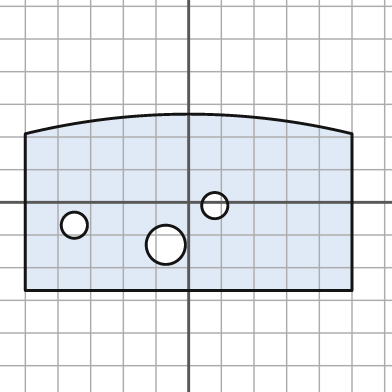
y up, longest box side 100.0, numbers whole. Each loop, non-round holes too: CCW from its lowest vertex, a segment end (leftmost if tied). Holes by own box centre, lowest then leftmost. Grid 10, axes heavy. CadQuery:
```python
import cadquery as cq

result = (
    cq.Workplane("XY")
    .moveTo(-50.0, -27.0)
    .lineTo(50.0, -27.0)
    .lineTo(50.0, 21.0)
    .threePointArc((0.0, 27.0), (-50.0, 21.0))
    .close()
    .moveTo(-7.0, -13.0)
    .circle(6.0)
    .moveTo(-35.0, -7.0)
    .circle(4.0)
    .moveTo(8.0, -1.0)
    .circle(4.0)
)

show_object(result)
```